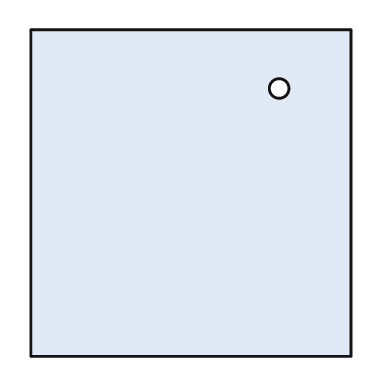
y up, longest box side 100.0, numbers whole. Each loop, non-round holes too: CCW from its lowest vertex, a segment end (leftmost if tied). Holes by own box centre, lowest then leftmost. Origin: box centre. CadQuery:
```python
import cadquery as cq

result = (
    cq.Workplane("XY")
    .moveTo(-49.0, -50.0)
    .lineTo(49.0, -50.0)
    .lineTo(49.0, 50.0)
    .lineTo(-49.0, 50.0)
    .close()
    .moveTo(27.0, 32.0)
    .circle(3.0)
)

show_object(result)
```